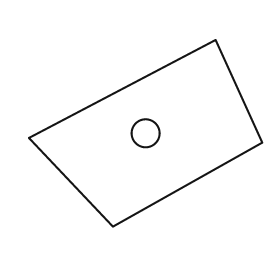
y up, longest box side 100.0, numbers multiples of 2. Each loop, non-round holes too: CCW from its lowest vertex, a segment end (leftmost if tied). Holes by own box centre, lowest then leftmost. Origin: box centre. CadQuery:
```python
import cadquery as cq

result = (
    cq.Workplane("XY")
    .moveTo(-14.0, -40.0)
    .lineTo(50.0, -4.0)
    .lineTo(30.0, 40.0)
    .lineTo(-50.0, -2.0)
    .close()
    .moveTo(0.0, 0.0)
    .circle(6.0)
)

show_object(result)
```